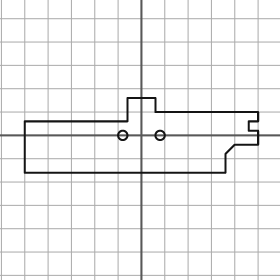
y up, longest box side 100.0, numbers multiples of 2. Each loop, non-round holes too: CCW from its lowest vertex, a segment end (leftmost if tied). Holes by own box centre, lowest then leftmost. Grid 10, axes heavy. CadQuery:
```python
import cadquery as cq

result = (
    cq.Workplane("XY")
    .moveTo(-50.0, -16.0)
    .lineTo(36.0, -16.0)
    .lineTo(36.0, -8.0)
    .lineTo(40.0, -4.0)
    .lineTo(50.0, -4.0)
    .lineTo(50.0, 2.0)
    .lineTo(46.0, 2.0)
    .lineTo(46.0, 6.0)
    .lineTo(50.0, 6.0)
    .lineTo(50.0, 10.0)
    .lineTo(6.0, 10.0)
    .lineTo(6.0, 16.0)
    .lineTo(-6.0, 16.0)
    .lineTo(-6.0, 6.0)
    .lineTo(-50.0, 6.0)
    .close()
    .moveTo(-8.0, 0.0)
    .circle(2.0)
    .moveTo(8.0, 0.0)
    .circle(2.0)
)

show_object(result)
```